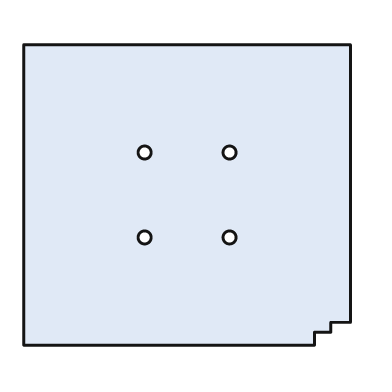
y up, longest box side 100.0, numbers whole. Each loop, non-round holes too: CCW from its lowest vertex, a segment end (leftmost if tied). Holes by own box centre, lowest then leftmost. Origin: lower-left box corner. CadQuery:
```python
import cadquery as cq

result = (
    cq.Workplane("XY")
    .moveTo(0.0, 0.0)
    .lineTo(89.0, 0.0)
    .lineTo(89.0, 4.0)
    .lineTo(94.0, 4.0)
    .lineTo(94.0, 7.0)
    .lineTo(100.0, 7.0)
    .lineTo(100.0, 92.0)
    .lineTo(0.0, 92.0)
    .close()
    .moveTo(37.0, 33.0)
    .circle(2.0)
    .moveTo(63.0, 33.0)
    .circle(2.0)
    .moveTo(37.0, 59.0)
    .circle(2.0)
    .moveTo(63.0, 59.0)
    .circle(2.0)
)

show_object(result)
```